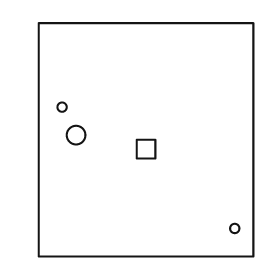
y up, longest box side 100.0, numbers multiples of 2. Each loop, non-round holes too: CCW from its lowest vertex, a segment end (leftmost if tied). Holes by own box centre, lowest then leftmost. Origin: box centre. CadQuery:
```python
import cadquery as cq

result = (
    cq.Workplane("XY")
    .moveTo(-46.0, -50.0)
    .lineTo(46.0, -50.0)
    .lineTo(46.0, 50.0)
    .lineTo(-46.0, 50.0)
    .close()
    .moveTo(38.0, -38.0)
    .circle(2.0)
    .moveTo(-4.0, -8.0)
    .lineTo(4.0, -8.0)
    .lineTo(4.0, 0.0)
    .lineTo(-4.0, 0.0)
    .close()
    .moveTo(-30.0, 2.0)
    .circle(4.0)
    .moveTo(-36.0, 14.0)
    .circle(2.0)
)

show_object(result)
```